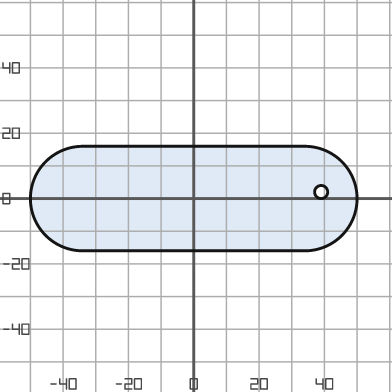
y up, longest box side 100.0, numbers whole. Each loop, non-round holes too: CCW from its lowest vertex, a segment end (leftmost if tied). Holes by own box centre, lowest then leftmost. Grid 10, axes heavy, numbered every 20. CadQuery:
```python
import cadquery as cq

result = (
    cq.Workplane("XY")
    .moveTo(-34.0, -16.0)
    .lineTo(34.0, -16.0)
    .threePointArc((50.0, 0.0), (34.0, 16.0))
    .lineTo(-34.0, 16.0)
    .threePointArc((-50.0, 0.0), (-34.0, -16.0))
    .close()
    .moveTo(39.0, 2.0)
    .circle(2.0)
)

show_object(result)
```